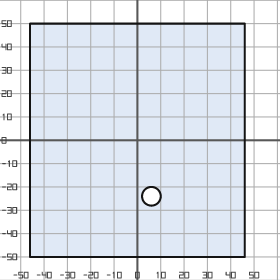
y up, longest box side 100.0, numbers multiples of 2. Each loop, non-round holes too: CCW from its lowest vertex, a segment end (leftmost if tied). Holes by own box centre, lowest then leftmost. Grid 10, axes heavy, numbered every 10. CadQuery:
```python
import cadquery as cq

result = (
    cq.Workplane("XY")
    .moveTo(-46.0, -50.0)
    .lineTo(46.0, -50.0)
    .lineTo(46.0, 50.0)
    .lineTo(-46.0, 50.0)
    .close()
    .moveTo(6.0, -24.0)
    .circle(4.0)
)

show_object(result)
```